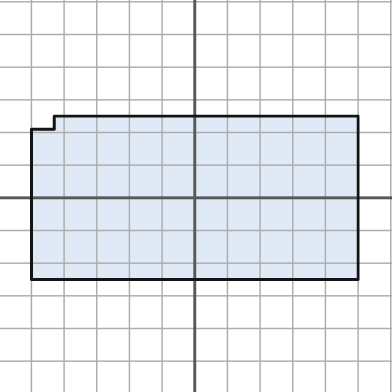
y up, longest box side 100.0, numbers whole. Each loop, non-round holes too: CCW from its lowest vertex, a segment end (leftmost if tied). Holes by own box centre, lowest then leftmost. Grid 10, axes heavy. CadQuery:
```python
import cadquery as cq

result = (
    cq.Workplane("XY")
    .moveTo(-50.0, -25.0)
    .lineTo(50.0, -25.0)
    .lineTo(50.0, 25.0)
    .lineTo(-43.0, 25.0)
    .lineTo(-43.0, 21.0)
    .lineTo(-50.0, 21.0)
    .close()
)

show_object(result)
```